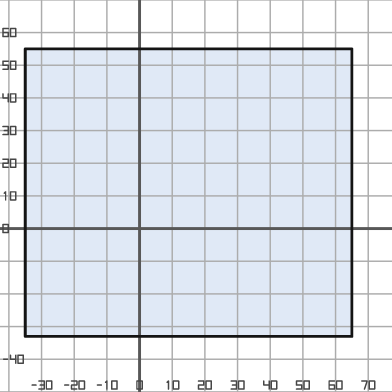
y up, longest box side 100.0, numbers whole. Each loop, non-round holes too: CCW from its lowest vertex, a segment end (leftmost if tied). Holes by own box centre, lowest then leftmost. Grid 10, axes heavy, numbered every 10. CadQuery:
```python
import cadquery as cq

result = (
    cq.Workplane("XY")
    .moveTo(-35.0, -33.0)
    .lineTo(65.0, -33.0)
    .lineTo(65.0, 55.0)
    .lineTo(-35.0, 55.0)
    .close()
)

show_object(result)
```